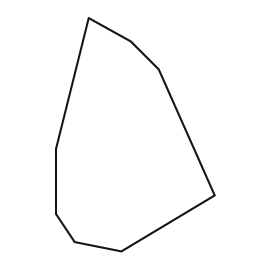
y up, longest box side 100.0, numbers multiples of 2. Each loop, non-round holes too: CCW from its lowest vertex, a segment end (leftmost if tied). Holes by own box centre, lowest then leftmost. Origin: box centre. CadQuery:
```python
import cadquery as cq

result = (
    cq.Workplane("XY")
    .moveTo(-6.0, -50.0)
    .lineTo(34.0, -26.0)
    .lineTo(10.0, 28.0)
    .lineTo(-2.0, 40.0)
    .lineTo(-20.0, 50.0)
    .lineTo(-34.0, -6.0)
    .lineTo(-34.0, -34.0)
    .lineTo(-26.0, -46.0)
    .close()
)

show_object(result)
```